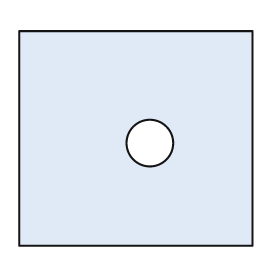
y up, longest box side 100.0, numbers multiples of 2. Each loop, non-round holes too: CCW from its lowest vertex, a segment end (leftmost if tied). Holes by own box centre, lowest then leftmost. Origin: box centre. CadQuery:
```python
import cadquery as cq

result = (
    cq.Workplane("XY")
    .moveTo(-50.0, -46.0)
    .lineTo(50.0, -46.0)
    .lineTo(50.0, 46.0)
    .lineTo(-50.0, 46.0)
    .close()
    .moveTo(6.0, -2.0)
    .circle(10.0)
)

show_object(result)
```